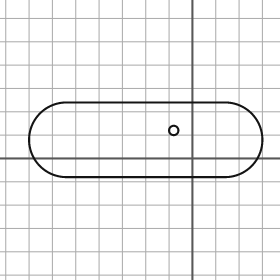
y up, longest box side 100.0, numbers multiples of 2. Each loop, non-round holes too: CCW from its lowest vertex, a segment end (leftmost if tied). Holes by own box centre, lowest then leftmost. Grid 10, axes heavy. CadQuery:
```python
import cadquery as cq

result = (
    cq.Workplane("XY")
    .moveTo(-54.0, -8.0)
    .lineTo(14.0, -8.0)
    .threePointArc((30.0, 8.0), (14.0, 24.0))
    .lineTo(-54.0, 24.0)
    .threePointArc((-70.0, 8.0), (-54.0, -8.0))
    .close()
    .moveTo(-8.0, 12.0)
    .circle(2.0)
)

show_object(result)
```